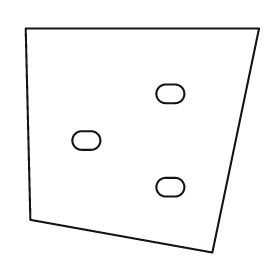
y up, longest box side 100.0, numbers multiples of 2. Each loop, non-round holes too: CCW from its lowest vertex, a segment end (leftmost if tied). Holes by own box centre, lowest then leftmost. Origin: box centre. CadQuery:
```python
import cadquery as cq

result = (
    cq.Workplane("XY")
    .moveTo(30.0, -48.0)
    .lineTo(50.0, 48.0)
    .lineTo(-50.0, 48.0)
    .lineTo(-48.0, -34.0)
    .close()
    .moveTo(10.0, -24.0)
    .lineTo(14.0, -24.0)
    .threePointArc((18.0, -20.0), (14.0, -16.0))
    .lineTo(10.0, -16.0)
    .threePointArc((6.0, -20.0), (10.0, -24.0))
    .close()
    .moveTo(-26.0, -4.0)
    .lineTo(-22.0, -4.0)
    .threePointArc((-18.0, 0.0), (-22.0, 4.0))
    .lineTo(-26.0, 4.0)
    .threePointArc((-30.0, 0.0), (-26.0, -4.0))
    .close()
    .moveTo(10.0, 16.0)
    .lineTo(14.0, 16.0)
    .threePointArc((18.0, 20.0), (14.0, 24.0))
    .lineTo(10.0, 24.0)
    .threePointArc((6.0, 20.0), (10.0, 16.0))
    .close()
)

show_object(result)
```